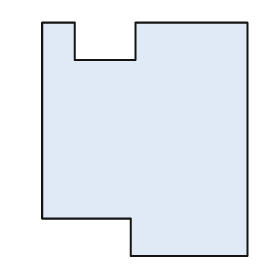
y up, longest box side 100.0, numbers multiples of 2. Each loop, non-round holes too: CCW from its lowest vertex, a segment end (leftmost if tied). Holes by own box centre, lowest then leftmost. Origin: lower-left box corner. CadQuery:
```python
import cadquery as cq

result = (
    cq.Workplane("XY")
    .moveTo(38.0, 0.0)
    .lineTo(88.0, 0.0)
    .lineTo(88.0, 100.0)
    .lineTo(40.0, 100.0)
    .lineTo(40.0, 84.0)
    .lineTo(14.0, 84.0)
    .lineTo(14.0, 100.0)
    .lineTo(0.0, 100.0)
    .lineTo(0.0, 16.0)
    .lineTo(38.0, 16.0)
    .close()
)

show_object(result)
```